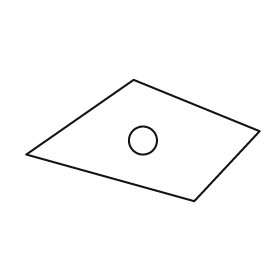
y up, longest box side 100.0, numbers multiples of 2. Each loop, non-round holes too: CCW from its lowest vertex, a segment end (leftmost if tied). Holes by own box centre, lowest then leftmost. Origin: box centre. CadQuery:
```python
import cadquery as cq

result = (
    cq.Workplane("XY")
    .moveTo(22.0, -26.0)
    .lineTo(50.0, 4.0)
    .lineTo(-4.0, 26.0)
    .lineTo(-50.0, -6.0)
    .close()
    .moveTo(0.0, 0.0)
    .circle(6.0)
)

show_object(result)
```